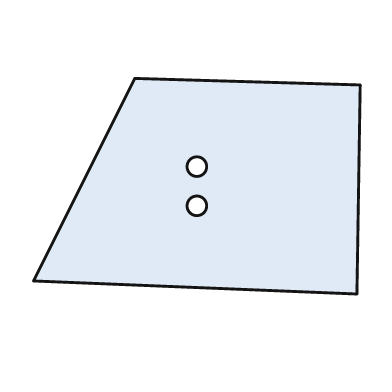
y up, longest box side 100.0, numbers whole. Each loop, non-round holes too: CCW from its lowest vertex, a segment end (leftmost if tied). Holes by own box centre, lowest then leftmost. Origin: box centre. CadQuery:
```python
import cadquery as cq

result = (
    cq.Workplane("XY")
    .moveTo(49.0, -33.0)
    .lineTo(50.0, 31.0)
    .lineTo(-19.0, 33.0)
    .lineTo(-50.0, -29.0)
    .close()
    .moveTo(0.0, -6.0)
    .circle(3.0)
    .moveTo(0.0, 6.0)
    .circle(3.0)
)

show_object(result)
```